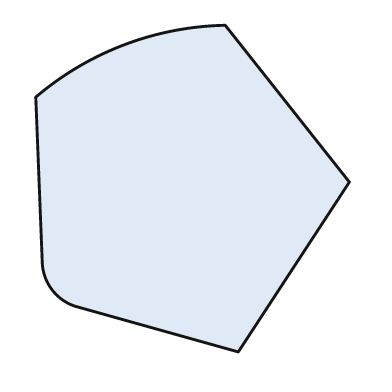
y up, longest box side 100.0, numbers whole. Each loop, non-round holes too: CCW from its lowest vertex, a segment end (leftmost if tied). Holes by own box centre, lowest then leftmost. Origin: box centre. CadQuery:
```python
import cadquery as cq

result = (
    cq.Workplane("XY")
    .moveTo(14.0, -50.0)
    .lineTo(48.0, 2.0)
    .lineTo(10.0, 50.0)
    .threePointArc((-21.0, 44.0), (-48.0, 28.0))
    .lineTo(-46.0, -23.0)
    .threePointArc((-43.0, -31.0), (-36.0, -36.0))
    .close()
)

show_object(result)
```